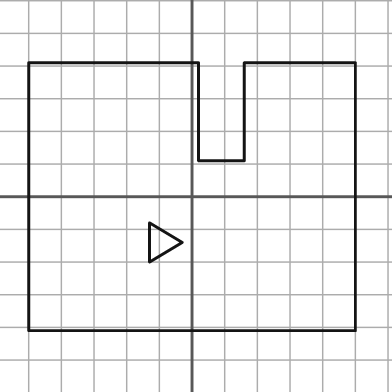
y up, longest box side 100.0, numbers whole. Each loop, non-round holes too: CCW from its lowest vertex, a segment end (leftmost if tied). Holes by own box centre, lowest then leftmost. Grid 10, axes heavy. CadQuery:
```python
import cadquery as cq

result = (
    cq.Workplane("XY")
    .moveTo(-50.0, -41.0)
    .lineTo(50.0, -41.0)
    .lineTo(50.0, 41.0)
    .lineTo(16.0, 41.0)
    .lineTo(16.0, 11.0)
    .lineTo(2.0, 11.0)
    .lineTo(2.0, 41.0)
    .lineTo(-50.0, 41.0)
    .close()
    .moveTo(-13.0, -20.0)
    .lineTo(-3.0, -14.0)
    .lineTo(-13.0, -8.0)
    .close()
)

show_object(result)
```